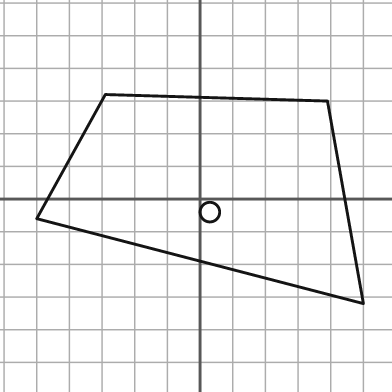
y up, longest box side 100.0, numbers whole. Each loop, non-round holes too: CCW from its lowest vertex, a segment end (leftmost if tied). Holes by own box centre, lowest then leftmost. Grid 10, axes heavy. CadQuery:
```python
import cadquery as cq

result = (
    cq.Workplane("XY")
    .moveTo(50.0, -32.0)
    .lineTo(39.0, 30.0)
    .lineTo(-29.0, 32.0)
    .lineTo(-50.0, -6.0)
    .close()
    .moveTo(3.0, -4.0)
    .circle(3.0)
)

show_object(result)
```